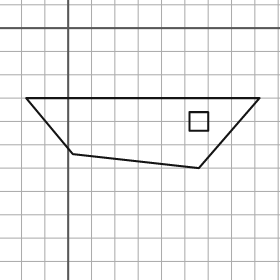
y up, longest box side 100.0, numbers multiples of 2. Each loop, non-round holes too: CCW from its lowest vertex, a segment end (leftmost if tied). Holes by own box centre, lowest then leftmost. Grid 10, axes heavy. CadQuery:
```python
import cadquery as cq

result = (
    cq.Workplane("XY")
    .moveTo(56.0, -60.0)
    .lineTo(82.0, -30.0)
    .lineTo(-18.0, -30.0)
    .lineTo(2.0, -54.0)
    .close()
    .moveTo(52.0, -44.0)
    .lineTo(60.0, -44.0)
    .lineTo(60.0, -36.0)
    .lineTo(52.0, -36.0)
    .close()
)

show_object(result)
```